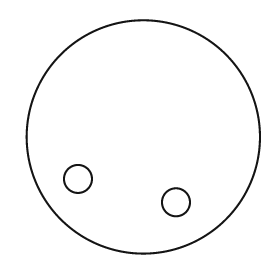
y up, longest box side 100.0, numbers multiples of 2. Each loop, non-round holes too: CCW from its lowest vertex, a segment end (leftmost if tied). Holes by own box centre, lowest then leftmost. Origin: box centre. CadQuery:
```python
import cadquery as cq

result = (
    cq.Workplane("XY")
    .moveTo(0.0, 0.0)
    .circle(50.0)
    .moveTo(14.0, -28.0)
    .circle(6.0)
    .moveTo(-28.0, -18.0)
    .circle(6.0)
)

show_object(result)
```